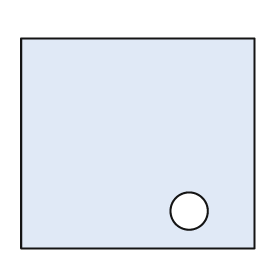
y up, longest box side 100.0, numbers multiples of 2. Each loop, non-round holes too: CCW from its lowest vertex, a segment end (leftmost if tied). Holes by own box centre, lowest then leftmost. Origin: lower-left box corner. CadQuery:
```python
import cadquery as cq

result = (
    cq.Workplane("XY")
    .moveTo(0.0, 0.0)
    .lineTo(100.0, 0.0)
    .lineTo(100.0, 90.0)
    .lineTo(0.0, 90.0)
    .close()
    .moveTo(72.0, 16.0)
    .circle(8.0)
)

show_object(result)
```